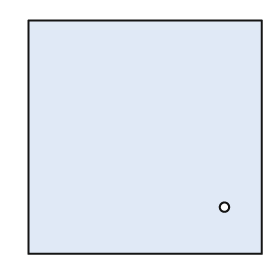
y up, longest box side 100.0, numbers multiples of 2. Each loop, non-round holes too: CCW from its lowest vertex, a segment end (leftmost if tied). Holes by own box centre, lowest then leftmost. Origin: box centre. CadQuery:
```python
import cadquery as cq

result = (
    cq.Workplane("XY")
    .moveTo(-50.0, -50.0)
    .lineTo(50.0, -50.0)
    .lineTo(50.0, 50.0)
    .lineTo(-50.0, 50.0)
    .close()
    .moveTo(34.0, -30.0)
    .circle(2.0)
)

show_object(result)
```